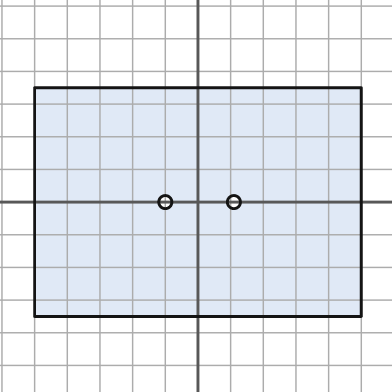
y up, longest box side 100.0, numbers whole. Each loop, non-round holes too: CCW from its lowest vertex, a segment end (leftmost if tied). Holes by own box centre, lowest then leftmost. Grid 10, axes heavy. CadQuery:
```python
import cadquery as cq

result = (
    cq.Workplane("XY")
    .moveTo(-50.0, -35.0)
    .lineTo(50.0, -35.0)
    .lineTo(50.0, 35.0)
    .lineTo(-50.0, 35.0)
    .close()
    .moveTo(-10.0, 0.0)
    .circle(2.0)
    .moveTo(11.0, 0.0)
    .circle(2.0)
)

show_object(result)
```